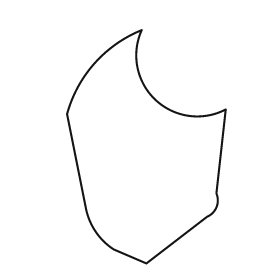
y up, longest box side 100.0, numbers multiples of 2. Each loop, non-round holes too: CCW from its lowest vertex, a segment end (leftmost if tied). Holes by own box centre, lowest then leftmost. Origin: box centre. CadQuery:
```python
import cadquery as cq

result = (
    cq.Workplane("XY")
    .moveTo(0.0, -50.0)
    .lineTo(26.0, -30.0)
    .threePointArc((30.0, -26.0), (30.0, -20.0))
    .lineTo(34.0, 16.0)
    .threePointArc((4.0, 20.0), (-2.0, 50.0))
    .threePointArc((-22.0, 36.0), (-34.0, 14.0))
    .lineTo(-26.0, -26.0)
    .threePointArc((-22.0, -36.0), (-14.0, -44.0))
    .close()
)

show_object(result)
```